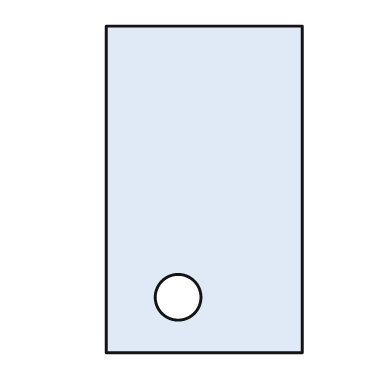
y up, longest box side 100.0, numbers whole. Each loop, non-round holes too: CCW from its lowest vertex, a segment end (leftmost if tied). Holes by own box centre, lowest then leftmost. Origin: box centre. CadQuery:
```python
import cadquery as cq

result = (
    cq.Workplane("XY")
    .moveTo(-30.0, -50.0)
    .lineTo(30.0, -50.0)
    .lineTo(30.0, 50.0)
    .lineTo(-30.0, 50.0)
    .close()
    .moveTo(-8.0, -33.0)
    .circle(7.0)
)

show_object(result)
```